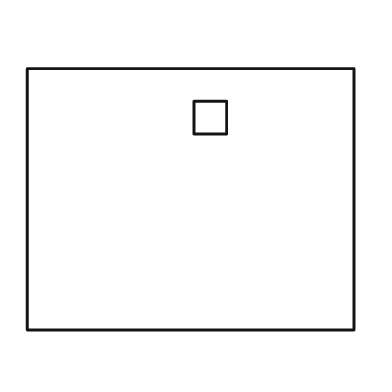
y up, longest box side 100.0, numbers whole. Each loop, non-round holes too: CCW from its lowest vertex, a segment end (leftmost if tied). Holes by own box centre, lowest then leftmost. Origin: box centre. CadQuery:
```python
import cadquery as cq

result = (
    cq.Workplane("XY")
    .moveTo(-50.0, -40.0)
    .lineTo(50.0, -40.0)
    .lineTo(50.0, 40.0)
    .lineTo(-50.0, 40.0)
    .close()
    .moveTo(1.0, 20.0)
    .lineTo(11.0, 20.0)
    .lineTo(11.0, 30.0)
    .lineTo(1.0, 30.0)
    .close()
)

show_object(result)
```